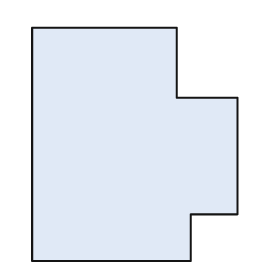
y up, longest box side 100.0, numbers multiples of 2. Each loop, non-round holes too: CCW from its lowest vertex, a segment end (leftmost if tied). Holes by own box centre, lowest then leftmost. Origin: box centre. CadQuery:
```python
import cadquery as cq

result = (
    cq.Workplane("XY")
    .moveTo(-44.0, -50.0)
    .lineTo(24.0, -50.0)
    .lineTo(24.0, -30.0)
    .lineTo(44.0, -30.0)
    .lineTo(44.0, 20.0)
    .lineTo(18.0, 20.0)
    .lineTo(18.0, 50.0)
    .lineTo(-44.0, 50.0)
    .close()
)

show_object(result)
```